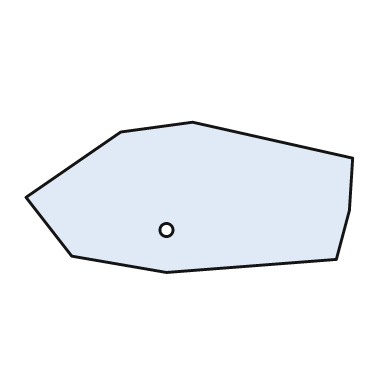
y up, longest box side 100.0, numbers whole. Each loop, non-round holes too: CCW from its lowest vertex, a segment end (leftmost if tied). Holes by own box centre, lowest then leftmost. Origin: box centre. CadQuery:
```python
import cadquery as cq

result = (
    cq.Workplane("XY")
    .moveTo(-7.0, -23.0)
    .lineTo(45.0, -19.0)
    .lineTo(49.0, -4.0)
    .lineTo(50.0, 12.0)
    .lineTo(1.0, 23.0)
    .lineTo(-21.0, 20.0)
    .lineTo(-50.0, 0.0)
    .lineTo(-36.0, -18.0)
    .close()
    .moveTo(-7.0, -10.0)
    .circle(2.0)
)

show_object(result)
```